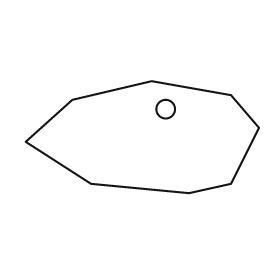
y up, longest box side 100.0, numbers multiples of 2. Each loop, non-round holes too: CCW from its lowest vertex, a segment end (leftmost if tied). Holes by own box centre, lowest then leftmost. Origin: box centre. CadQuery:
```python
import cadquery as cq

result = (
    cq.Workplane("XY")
    .moveTo(20.0, -24.0)
    .lineTo(38.0, -20.0)
    .lineTo(50.0, 4.0)
    .lineTo(38.0, 18.0)
    .lineTo(4.0, 24.0)
    .lineTo(-30.0, 16.0)
    .lineTo(-50.0, -2.0)
    .lineTo(-22.0, -20.0)
    .close()
    .moveTo(10.0, 12.0)
    .circle(4.0)
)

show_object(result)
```